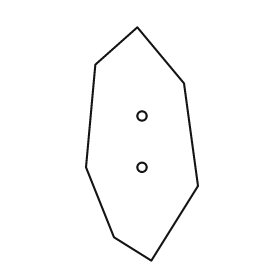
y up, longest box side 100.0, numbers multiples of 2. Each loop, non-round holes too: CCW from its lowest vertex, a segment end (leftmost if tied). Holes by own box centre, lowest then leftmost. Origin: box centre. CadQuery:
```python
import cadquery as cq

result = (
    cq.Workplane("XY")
    .moveTo(4.0, -50.0)
    .lineTo(24.0, -18.0)
    .lineTo(18.0, 26.0)
    .lineTo(-2.0, 50.0)
    .lineTo(-20.0, 34.0)
    .lineTo(-24.0, -10.0)
    .lineTo(-12.0, -40.0)
    .close()
    .moveTo(0.0, -10.0)
    .circle(2.0)
    .moveTo(0.0, 12.0)
    .circle(2.0)
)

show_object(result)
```